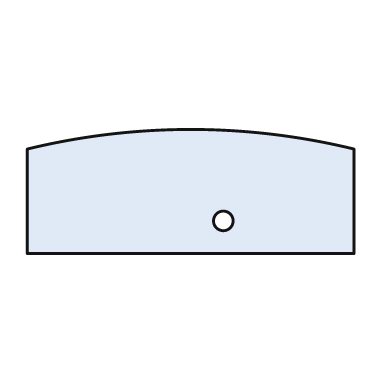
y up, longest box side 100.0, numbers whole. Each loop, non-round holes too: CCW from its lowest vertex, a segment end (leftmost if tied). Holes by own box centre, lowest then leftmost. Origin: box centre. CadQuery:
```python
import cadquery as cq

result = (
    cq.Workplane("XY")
    .moveTo(-50.0, -19.0)
    .lineTo(50.0, -19.0)
    .lineTo(50.0, 13.0)
    .threePointArc((0.0, 19.0), (-50.0, 13.0))
    .close()
    .moveTo(10.0, -9.0)
    .circle(3.0)
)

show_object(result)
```